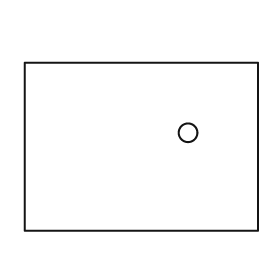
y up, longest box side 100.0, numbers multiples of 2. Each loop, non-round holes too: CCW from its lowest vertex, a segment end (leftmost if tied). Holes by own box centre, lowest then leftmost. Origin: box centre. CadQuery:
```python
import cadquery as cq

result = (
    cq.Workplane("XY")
    .moveTo(-50.0, -36.0)
    .lineTo(50.0, -36.0)
    .lineTo(50.0, 36.0)
    .lineTo(-50.0, 36.0)
    .close()
    .moveTo(20.0, 6.0)
    .circle(4.0)
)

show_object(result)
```